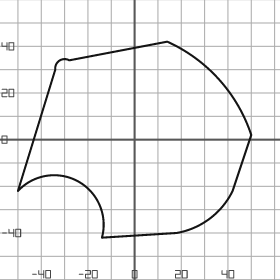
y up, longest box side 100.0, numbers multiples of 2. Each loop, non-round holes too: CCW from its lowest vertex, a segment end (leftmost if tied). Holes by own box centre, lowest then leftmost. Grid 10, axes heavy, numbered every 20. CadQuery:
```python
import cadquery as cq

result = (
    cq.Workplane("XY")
    .moveTo(-14.0, -42.0)
    .lineTo(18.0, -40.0)
    .threePointArc((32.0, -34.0), (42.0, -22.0))
    .lineTo(50.0, 2.0)
    .threePointArc((36.0, 26.0), (14.0, 42.0))
    .lineTo(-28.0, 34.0)
    .threePointArc((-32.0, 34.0), (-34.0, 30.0))
    .lineTo(-50.0, -22.0)
    .threePointArc((-24.0, -18.0), (-14.0, -42.0))
    .close()
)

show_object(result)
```